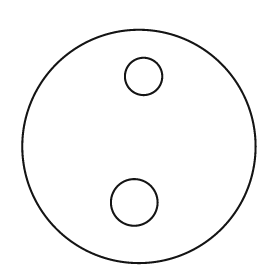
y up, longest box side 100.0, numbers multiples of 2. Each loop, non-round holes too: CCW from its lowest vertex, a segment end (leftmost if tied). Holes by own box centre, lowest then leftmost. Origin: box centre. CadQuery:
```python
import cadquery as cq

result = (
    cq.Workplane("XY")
    .moveTo(0.0, 0.0)
    .circle(50.0)
    .moveTo(-2.0, -24.0)
    .circle(10.0)
    .moveTo(2.0, 30.0)
    .circle(8.0)
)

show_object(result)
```